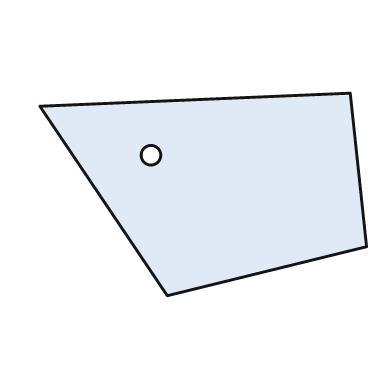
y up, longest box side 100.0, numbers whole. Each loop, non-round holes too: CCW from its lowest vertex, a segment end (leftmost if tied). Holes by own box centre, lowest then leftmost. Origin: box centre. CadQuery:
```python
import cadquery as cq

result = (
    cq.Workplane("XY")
    .moveTo(-11.0, -31.0)
    .lineTo(50.0, -16.0)
    .lineTo(45.0, 31.0)
    .lineTo(-50.0, 27.0)
    .close()
    .moveTo(-16.0, 12.0)
    .circle(3.0)
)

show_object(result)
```